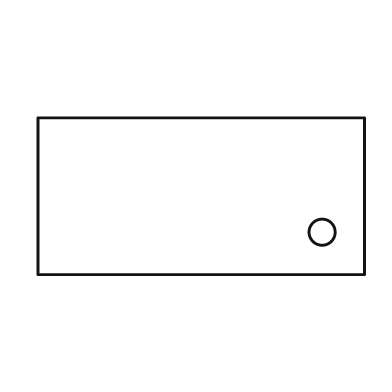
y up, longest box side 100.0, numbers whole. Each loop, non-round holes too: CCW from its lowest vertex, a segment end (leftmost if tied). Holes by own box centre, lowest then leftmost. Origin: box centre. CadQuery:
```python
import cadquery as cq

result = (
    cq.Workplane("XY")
    .moveTo(-50.0, -24.0)
    .lineTo(50.0, -24.0)
    .lineTo(50.0, 24.0)
    .lineTo(-50.0, 24.0)
    .close()
    .moveTo(37.0, -11.0)
    .circle(4.0)
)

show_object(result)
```